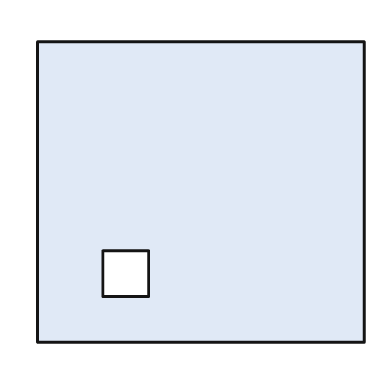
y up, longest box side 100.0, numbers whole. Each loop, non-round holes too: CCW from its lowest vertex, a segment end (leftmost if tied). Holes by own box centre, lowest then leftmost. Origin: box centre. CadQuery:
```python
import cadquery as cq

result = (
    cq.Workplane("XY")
    .moveTo(-50.0, -46.0)
    .lineTo(50.0, -46.0)
    .lineTo(50.0, 46.0)
    .lineTo(-50.0, 46.0)
    .close()
    .moveTo(-30.0, -32.0)
    .lineTo(-16.0, -32.0)
    .lineTo(-16.0, -18.0)
    .lineTo(-30.0, -18.0)
    .close()
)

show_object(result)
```